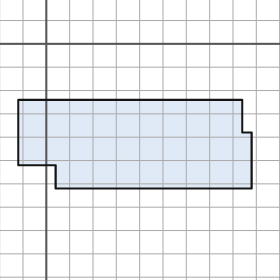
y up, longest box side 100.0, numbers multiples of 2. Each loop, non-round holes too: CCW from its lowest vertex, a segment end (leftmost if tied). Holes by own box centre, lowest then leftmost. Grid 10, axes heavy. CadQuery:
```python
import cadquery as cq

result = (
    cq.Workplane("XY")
    .moveTo(4.0, -62.0)
    .lineTo(88.0, -62.0)
    .lineTo(88.0, -38.0)
    .lineTo(84.0, -38.0)
    .lineTo(84.0, -24.0)
    .lineTo(-12.0, -24.0)
    .lineTo(-12.0, -52.0)
    .lineTo(4.0, -52.0)
    .close()
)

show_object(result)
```